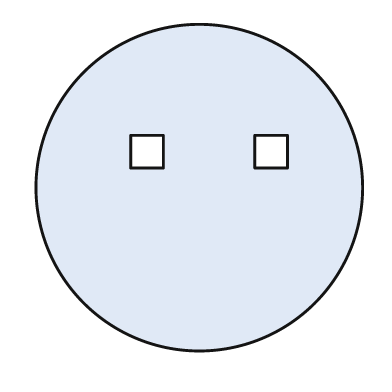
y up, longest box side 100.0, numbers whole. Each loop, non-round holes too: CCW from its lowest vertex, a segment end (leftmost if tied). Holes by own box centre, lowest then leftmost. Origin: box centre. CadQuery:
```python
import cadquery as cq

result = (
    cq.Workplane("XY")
    .moveTo(0.0, 0.0)
    .circle(50.0)
    .moveTo(-21.0, 6.0)
    .lineTo(-11.0, 6.0)
    .lineTo(-11.0, 16.0)
    .lineTo(-21.0, 16.0)
    .close()
    .moveTo(17.0, 6.0)
    .lineTo(27.0, 6.0)
    .lineTo(27.0, 16.0)
    .lineTo(17.0, 16.0)
    .close()
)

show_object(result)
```